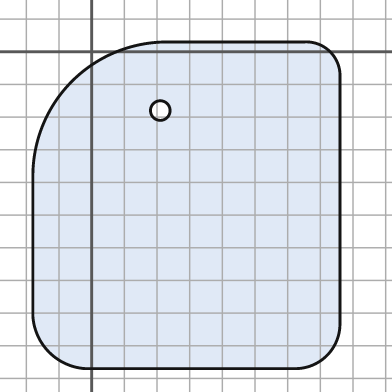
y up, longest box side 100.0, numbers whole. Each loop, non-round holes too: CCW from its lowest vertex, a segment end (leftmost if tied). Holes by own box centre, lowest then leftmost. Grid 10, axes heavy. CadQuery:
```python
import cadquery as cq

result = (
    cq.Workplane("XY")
    .moveTo(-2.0, -97.0)
    .lineTo(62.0, -97.0)
    .threePointArc((72.0, -93.0), (76.0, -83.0))
    .lineTo(76.0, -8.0)
    .threePointArc((73.0, 0.0), (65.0, 3.0))
    .lineTo(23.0, 3.0)
    .threePointArc((-6.0, -9.0), (-18.0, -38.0))
    .lineTo(-18.0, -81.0)
    .threePointArc((-13.0, -92.0), (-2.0, -97.0))
    .close()
    .moveTo(21.0, -18.0)
    .circle(3.0)
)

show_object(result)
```